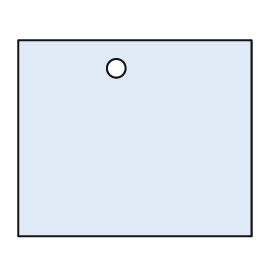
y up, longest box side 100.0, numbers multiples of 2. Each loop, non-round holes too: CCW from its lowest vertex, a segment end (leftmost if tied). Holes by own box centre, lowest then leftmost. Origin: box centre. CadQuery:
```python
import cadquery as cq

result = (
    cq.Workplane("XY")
    .moveTo(-50.0, -42.0)
    .lineTo(50.0, -42.0)
    .lineTo(50.0, 42.0)
    .lineTo(-50.0, 42.0)
    .close()
    .moveTo(-8.0, 30.0)
    .circle(4.0)
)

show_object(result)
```